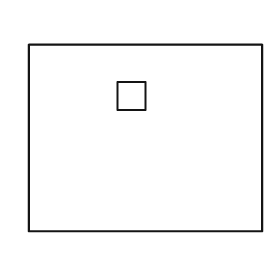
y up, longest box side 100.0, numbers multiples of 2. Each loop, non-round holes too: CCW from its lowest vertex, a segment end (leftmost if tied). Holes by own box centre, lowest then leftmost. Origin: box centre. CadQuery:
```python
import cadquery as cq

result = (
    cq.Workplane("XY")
    .moveTo(-50.0, -40.0)
    .lineTo(50.0, -40.0)
    .lineTo(50.0, 40.0)
    .lineTo(-50.0, 40.0)
    .close()
    .moveTo(-12.0, 12.0)
    .lineTo(0.0, 12.0)
    .lineTo(0.0, 24.0)
    .lineTo(-12.0, 24.0)
    .close()
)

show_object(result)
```